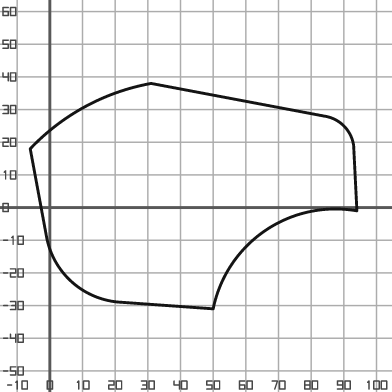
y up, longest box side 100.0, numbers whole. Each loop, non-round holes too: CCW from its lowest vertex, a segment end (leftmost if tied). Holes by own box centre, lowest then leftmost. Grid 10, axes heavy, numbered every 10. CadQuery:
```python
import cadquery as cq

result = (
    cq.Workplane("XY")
    .moveTo(50.0, -31.0)
    .threePointArc((66.0, -7.0), (94.0, -1.0))
    .lineTo(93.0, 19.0)
    .threePointArc((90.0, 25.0), (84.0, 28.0))
    .lineTo(31.0, 38.0)
    .threePointArc((11.0, 31.0), (-6.0, 18.0))
    .lineTo(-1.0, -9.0)
    .threePointArc((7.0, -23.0), (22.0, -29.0))
    .close()
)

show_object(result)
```